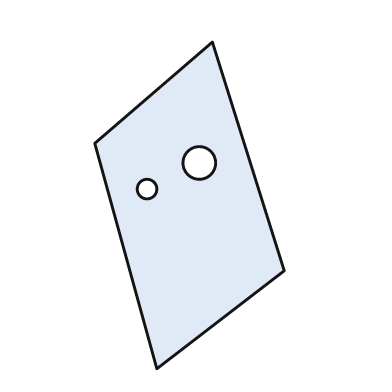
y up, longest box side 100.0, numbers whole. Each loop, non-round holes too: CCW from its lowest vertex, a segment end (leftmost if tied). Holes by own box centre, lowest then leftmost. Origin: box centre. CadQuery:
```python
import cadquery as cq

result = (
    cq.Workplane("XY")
    .moveTo(-10.0, -50.0)
    .lineTo(29.0, -20.0)
    .lineTo(7.0, 50.0)
    .lineTo(-29.0, 19.0)
    .close()
    .moveTo(-13.0, 5.0)
    .circle(3.0)
    .moveTo(3.0, 13.0)
    .circle(5.0)
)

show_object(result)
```